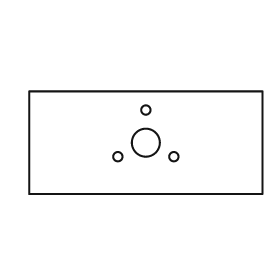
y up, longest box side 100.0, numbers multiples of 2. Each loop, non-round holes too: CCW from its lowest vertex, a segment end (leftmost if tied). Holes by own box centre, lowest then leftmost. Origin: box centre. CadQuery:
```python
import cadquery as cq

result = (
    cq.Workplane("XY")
    .moveTo(-50.0, -22.0)
    .lineTo(50.0, -22.0)
    .lineTo(50.0, 22.0)
    .lineTo(-50.0, 22.0)
    .close()
    .moveTo(-12.0, -6.0)
    .circle(2.0)
    .moveTo(12.0, -6.0)
    .circle(2.0)
    .moveTo(0.0, 0.0)
    .circle(6.0)
    .moveTo(0.0, 14.0)
    .circle(2.0)
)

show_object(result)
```